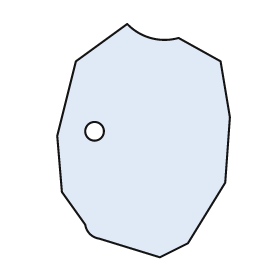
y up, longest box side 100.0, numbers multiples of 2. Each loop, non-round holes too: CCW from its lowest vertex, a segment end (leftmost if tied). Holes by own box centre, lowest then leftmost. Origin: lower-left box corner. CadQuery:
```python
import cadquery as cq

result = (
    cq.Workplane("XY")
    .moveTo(44.0, 0.0)
    .lineTo(56.0, 6.0)
    .lineTo(72.0, 32.0)
    .lineTo(74.0, 60.0)
    .lineTo(70.0, 84.0)
    .lineTo(52.0, 94.0)
    .threePointArc((40.0, 94.0), (30.0, 100.0))
    .lineTo(8.0, 84.0)
    .lineTo(0.0, 52.0)
    .lineTo(2.0, 28.0)
    .lineTo(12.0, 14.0)
    .threePointArc((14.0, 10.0), (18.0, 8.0))
    .close()
    .moveTo(16.0, 54.0)
    .circle(4.0)
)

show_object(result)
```